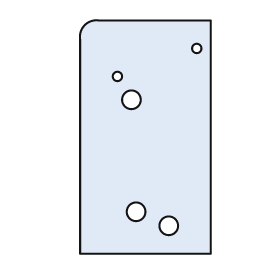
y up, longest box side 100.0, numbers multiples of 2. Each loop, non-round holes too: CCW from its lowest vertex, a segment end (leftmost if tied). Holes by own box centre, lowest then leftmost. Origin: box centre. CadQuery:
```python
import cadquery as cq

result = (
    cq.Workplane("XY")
    .moveTo(-28.0, -50.0)
    .lineTo(28.0, -50.0)
    .lineTo(28.0, 50.0)
    .lineTo(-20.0, 50.0)
    .threePointArc((-26.0, 48.0), (-28.0, 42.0))
    .close()
    .moveTo(10.0, -38.0)
    .circle(4.0)
    .moveTo(-4.0, -32.0)
    .circle(4.0)
    .moveTo(-6.0, 16.0)
    .circle(4.0)
    .moveTo(-12.0, 26.0)
    .circle(2.0)
    .moveTo(22.0, 38.0)
    .circle(2.0)
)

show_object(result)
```